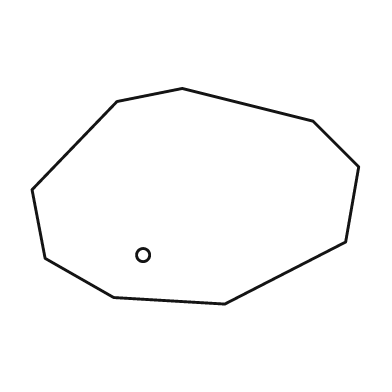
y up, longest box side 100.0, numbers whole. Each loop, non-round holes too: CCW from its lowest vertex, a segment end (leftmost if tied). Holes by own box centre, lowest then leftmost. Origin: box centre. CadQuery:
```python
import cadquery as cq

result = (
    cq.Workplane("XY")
    .moveTo(9.0, -33.0)
    .lineTo(46.0, -14.0)
    .lineTo(50.0, 9.0)
    .lineTo(36.0, 23.0)
    .lineTo(-4.0, 33.0)
    .lineTo(-24.0, 29.0)
    .lineTo(-50.0, 2.0)
    .lineTo(-46.0, -19.0)
    .lineTo(-25.0, -31.0)
    .close()
    .moveTo(-16.0, -18.0)
    .circle(2.0)
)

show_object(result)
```